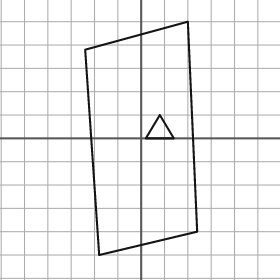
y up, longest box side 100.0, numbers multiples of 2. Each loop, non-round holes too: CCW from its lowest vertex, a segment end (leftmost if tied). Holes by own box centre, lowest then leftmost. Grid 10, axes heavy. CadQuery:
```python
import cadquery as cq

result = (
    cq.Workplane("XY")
    .moveTo(-18.0, -50.0)
    .lineTo(24.0, -40.0)
    .lineTo(20.0, 50.0)
    .lineTo(-24.0, 38.0)
    .close()
    .moveTo(2.0, 0.0)
    .lineTo(14.0, 0.0)
    .lineTo(8.0, 10.0)
    .close()
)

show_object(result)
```